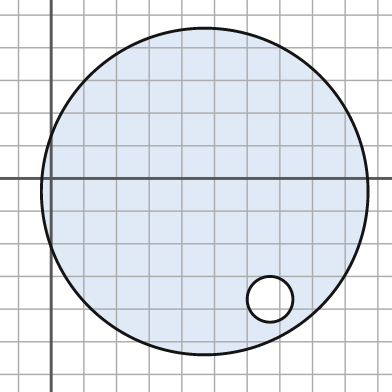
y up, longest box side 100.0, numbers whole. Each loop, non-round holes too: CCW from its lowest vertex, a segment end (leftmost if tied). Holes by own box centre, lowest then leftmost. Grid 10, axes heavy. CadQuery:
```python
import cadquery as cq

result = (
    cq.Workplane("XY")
    .moveTo(47.0, -4.0)
    .circle(50.0)
    .moveTo(67.0, -37.0)
    .circle(7.0)
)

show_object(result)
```